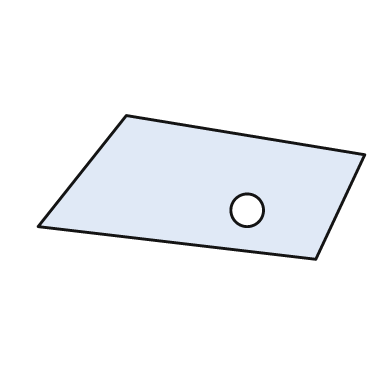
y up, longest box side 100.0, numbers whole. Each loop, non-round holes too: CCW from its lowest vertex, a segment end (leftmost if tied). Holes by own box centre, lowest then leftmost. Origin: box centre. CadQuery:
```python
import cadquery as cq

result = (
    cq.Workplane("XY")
    .moveTo(35.0, -22.0)
    .lineTo(50.0, 10.0)
    .lineTo(-23.0, 22.0)
    .lineTo(-50.0, -12.0)
    .close()
    .moveTo(14.0, -7.0)
    .circle(5.0)
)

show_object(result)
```